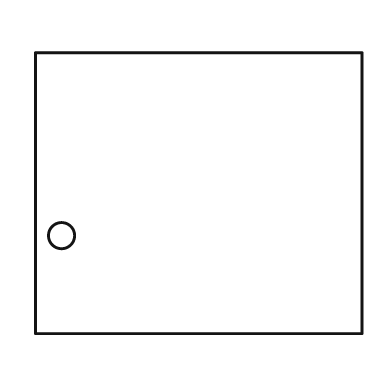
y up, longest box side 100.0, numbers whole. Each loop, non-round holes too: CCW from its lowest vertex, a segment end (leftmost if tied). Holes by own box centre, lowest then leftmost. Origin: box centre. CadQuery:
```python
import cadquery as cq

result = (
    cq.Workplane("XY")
    .moveTo(-50.0, -43.0)
    .lineTo(50.0, -43.0)
    .lineTo(50.0, 43.0)
    .lineTo(-50.0, 43.0)
    .close()
    .moveTo(-42.0, -13.0)
    .circle(4.0)
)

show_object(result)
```